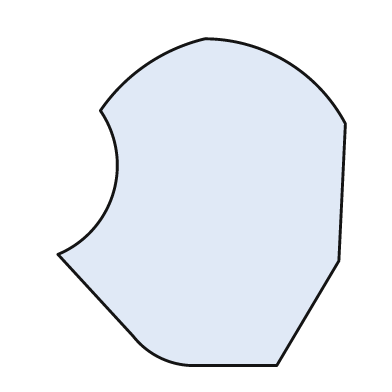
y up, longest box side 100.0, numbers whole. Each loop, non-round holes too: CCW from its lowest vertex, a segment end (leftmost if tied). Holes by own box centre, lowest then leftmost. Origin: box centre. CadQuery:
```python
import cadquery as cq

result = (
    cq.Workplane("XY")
    .moveTo(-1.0, -50.0)
    .lineTo(23.0, -50.0)
    .lineTo(42.0, -18.0)
    .lineTo(44.0, 24.0)
    .threePointArc((26.0, 43.0), (1.0, 50.0))
    .threePointArc((-17.0, 42.0), (-31.0, 28.0))
    .threePointArc((-27.0, 3.0), (-44.0, -16.0))
    .lineTo(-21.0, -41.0)
    .threePointArc((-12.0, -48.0), (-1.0, -50.0))
    .close()
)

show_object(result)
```